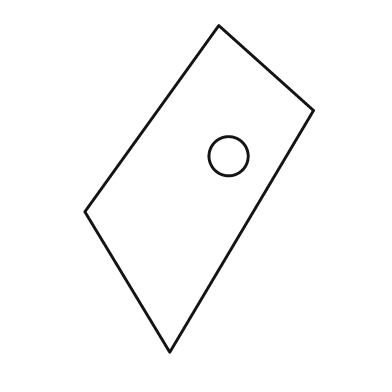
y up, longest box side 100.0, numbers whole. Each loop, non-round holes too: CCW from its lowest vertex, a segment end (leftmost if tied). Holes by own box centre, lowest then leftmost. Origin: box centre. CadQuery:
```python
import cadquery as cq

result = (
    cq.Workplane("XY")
    .moveTo(-9.0, -50.0)
    .lineTo(35.0, 24.0)
    .lineTo(6.0, 50.0)
    .lineTo(-35.0, -7.0)
    .close()
    .moveTo(9.0, 10.0)
    .circle(6.0)
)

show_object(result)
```